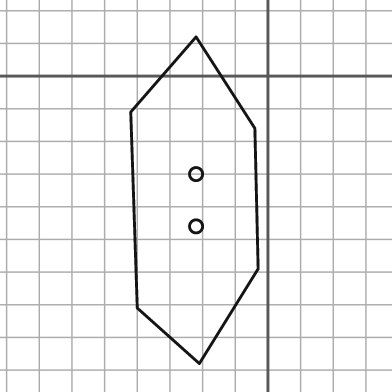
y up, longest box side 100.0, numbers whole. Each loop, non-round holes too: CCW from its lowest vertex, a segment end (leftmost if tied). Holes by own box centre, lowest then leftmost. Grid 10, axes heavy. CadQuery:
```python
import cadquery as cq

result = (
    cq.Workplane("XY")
    .moveTo(-21.0, -88.0)
    .lineTo(-3.0, -59.0)
    .lineTo(-4.0, -16.0)
    .lineTo(-22.0, 12.0)
    .lineTo(-42.0, -11.0)
    .lineTo(-40.0, -71.0)
    .close()
    .moveTo(-22.0, -46.0)
    .circle(2.0)
    .moveTo(-22.0, -30.0)
    .circle(2.0)
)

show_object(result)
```